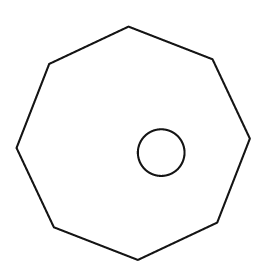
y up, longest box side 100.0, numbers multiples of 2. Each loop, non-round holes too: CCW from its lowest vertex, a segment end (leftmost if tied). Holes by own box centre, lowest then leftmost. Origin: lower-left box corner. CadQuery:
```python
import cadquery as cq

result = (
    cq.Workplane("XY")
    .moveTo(52.0, 0.0)
    .lineTo(86.0, 16.0)
    .lineTo(100.0, 52.0)
    .lineTo(84.0, 86.0)
    .lineTo(48.0, 100.0)
    .lineTo(14.0, 84.0)
    .lineTo(0.0, 48.0)
    .lineTo(16.0, 14.0)
    .close()
    .moveTo(62.0, 46.0)
    .circle(10.0)
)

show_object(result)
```